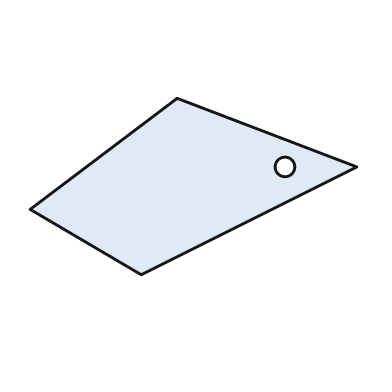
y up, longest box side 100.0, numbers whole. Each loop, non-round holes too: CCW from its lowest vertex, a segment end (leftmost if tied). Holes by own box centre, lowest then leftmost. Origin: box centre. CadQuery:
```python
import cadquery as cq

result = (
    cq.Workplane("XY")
    .moveTo(-16.0, -27.0)
    .lineTo(50.0, 6.0)
    .lineTo(-5.0, 27.0)
    .lineTo(-50.0, -7.0)
    .close()
    .moveTo(28.0, 6.0)
    .circle(3.0)
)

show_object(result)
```